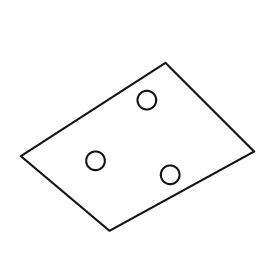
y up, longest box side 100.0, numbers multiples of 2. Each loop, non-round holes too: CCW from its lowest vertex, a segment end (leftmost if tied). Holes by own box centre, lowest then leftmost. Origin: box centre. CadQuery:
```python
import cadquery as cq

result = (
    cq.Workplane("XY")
    .moveTo(-12.0, -36.0)
    .lineTo(50.0, -2.0)
    .lineTo(12.0, 36.0)
    .lineTo(-50.0, -4.0)
    .close()
    .moveTo(14.0, -12.0)
    .circle(4.0)
    .moveTo(-18.0, -6.0)
    .circle(4.0)
    .moveTo(4.0, 20.0)
    .circle(4.0)
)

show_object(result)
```